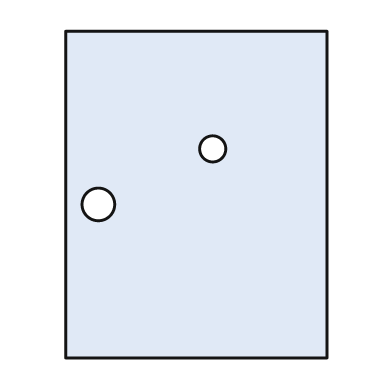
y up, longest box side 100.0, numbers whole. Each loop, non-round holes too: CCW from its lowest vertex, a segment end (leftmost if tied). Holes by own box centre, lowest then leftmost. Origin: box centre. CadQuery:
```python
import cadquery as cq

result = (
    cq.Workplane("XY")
    .moveTo(-40.0, -50.0)
    .lineTo(40.0, -50.0)
    .lineTo(40.0, 50.0)
    .lineTo(-40.0, 50.0)
    .close()
    .moveTo(-30.0, -3.0)
    .circle(5.0)
    .moveTo(5.0, 14.0)
    .circle(4.0)
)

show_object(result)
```